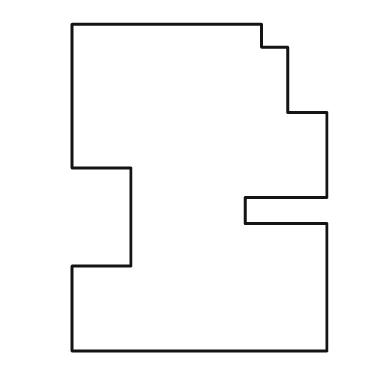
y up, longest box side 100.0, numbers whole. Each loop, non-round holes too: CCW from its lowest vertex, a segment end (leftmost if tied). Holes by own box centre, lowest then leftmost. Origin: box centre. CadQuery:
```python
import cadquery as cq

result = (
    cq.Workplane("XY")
    .moveTo(-39.0, -50.0)
    .lineTo(39.0, -50.0)
    .lineTo(39.0, -11.0)
    .lineTo(14.0, -11.0)
    .lineTo(14.0, -3.0)
    .lineTo(39.0, -3.0)
    .lineTo(39.0, 23.0)
    .lineTo(27.0, 23.0)
    .lineTo(27.0, 43.0)
    .lineTo(19.0, 43.0)
    .lineTo(19.0, 50.0)
    .lineTo(-39.0, 50.0)
    .lineTo(-39.0, 6.0)
    .lineTo(-21.0, 6.0)
    .lineTo(-21.0, -24.0)
    .lineTo(-39.0, -24.0)
    .close()
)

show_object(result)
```